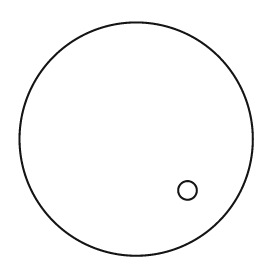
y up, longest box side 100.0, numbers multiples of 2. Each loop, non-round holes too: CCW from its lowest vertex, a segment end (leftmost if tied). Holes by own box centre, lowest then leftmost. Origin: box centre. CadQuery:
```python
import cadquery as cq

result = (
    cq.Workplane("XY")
    .moveTo(0.0, 0.0)
    .circle(50.0)
    .moveTo(22.0, -22.0)
    .circle(4.0)
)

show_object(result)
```